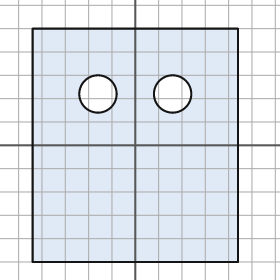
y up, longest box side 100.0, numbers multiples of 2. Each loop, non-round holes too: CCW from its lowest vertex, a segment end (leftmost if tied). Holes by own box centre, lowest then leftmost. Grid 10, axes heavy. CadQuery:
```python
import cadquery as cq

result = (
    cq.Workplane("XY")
    .moveTo(-44.0, -50.0)
    .lineTo(44.0, -50.0)
    .lineTo(44.0, 50.0)
    .lineTo(-44.0, 50.0)
    .close()
    .moveTo(-16.0, 22.0)
    .circle(8.0)
    .moveTo(16.0, 22.0)
    .circle(8.0)
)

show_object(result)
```